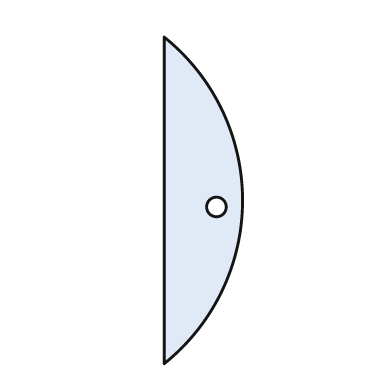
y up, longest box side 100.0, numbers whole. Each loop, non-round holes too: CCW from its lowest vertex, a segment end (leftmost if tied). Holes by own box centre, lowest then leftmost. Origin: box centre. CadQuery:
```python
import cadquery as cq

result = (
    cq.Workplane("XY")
    .moveTo(-12.0, -50.0)
    .threePointArc((12.0, 0.0), (-12.0, 50.0))
    .close()
    .moveTo(4.0, -2.0)
    .circle(3.0)
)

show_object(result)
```